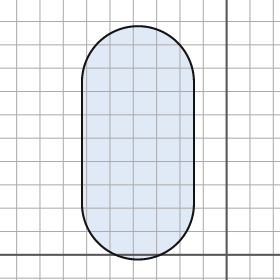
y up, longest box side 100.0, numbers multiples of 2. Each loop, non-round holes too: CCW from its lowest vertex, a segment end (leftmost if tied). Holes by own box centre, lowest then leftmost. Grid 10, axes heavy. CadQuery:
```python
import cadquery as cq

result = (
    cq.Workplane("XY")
    .moveTo(-62.0, 22.0)
    .threePointArc((-38.0, -2.0), (-14.0, 22.0))
    .lineTo(-14.0, 74.0)
    .threePointArc((-38.0, 98.0), (-62.0, 74.0))
    .close()
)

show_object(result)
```